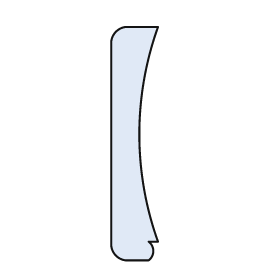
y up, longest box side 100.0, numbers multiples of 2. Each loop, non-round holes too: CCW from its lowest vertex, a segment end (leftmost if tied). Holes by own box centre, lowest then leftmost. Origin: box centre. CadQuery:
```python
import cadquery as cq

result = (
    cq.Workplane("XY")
    .moveTo(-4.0, -50.0)
    .lineTo(6.0, -50.0)
    .threePointArc((8.0, -46.0), (6.0, -42.0))
    .lineTo(10.0, -42.0)
    .threePointArc((2.0, 4.0), (10.0, 50.0))
    .lineTo(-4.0, 50.0)
    .threePointArc((-8.0, 48.0), (-10.0, 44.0))
    .lineTo(-10.0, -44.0)
    .threePointArc((-8.0, -48.0), (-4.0, -50.0))
    .close()
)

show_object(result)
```